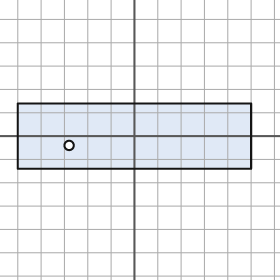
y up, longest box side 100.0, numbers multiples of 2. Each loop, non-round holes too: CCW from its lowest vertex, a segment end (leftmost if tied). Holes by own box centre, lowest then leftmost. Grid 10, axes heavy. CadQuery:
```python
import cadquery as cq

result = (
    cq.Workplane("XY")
    .moveTo(-50.0, -14.0)
    .lineTo(50.0, -14.0)
    .lineTo(50.0, 14.0)
    .lineTo(-50.0, 14.0)
    .close()
    .moveTo(-28.0, -4.0)
    .circle(2.0)
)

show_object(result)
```